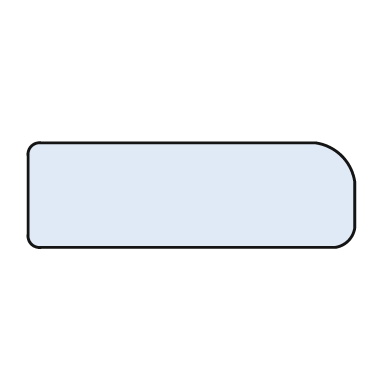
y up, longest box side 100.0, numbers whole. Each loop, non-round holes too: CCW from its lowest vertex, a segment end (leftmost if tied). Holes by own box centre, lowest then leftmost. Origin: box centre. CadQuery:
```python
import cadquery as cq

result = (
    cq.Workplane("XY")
    .moveTo(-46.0, -16.0)
    .lineTo(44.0, -16.0)
    .threePointArc((48.0, -14.0), (50.0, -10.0))
    .lineTo(50.0, 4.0)
    .threePointArc((46.0, 12.0), (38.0, 16.0))
    .lineTo(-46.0, 16.0)
    .threePointArc((-49.0, 15.0), (-50.0, 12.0))
    .lineTo(-50.0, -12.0)
    .threePointArc((-49.0, -15.0), (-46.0, -16.0))
    .close()
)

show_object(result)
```